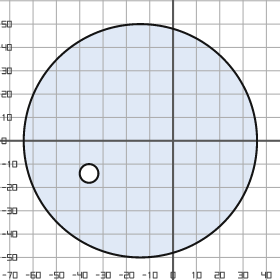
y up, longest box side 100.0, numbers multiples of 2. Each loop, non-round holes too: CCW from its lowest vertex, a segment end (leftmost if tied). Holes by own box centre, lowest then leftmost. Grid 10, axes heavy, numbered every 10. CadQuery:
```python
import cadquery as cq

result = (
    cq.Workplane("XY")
    .moveTo(-14.0, 0.0)
    .circle(50.0)
    .moveTo(-36.0, -14.0)
    .circle(4.0)
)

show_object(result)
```